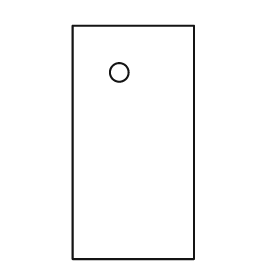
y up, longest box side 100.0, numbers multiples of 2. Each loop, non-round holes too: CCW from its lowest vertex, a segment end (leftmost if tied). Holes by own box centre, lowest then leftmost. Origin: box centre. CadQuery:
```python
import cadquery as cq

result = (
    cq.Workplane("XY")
    .moveTo(-26.0, -50.0)
    .lineTo(26.0, -50.0)
    .lineTo(26.0, 50.0)
    .lineTo(-26.0, 50.0)
    .close()
    .moveTo(-6.0, 30.0)
    .circle(4.0)
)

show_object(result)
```